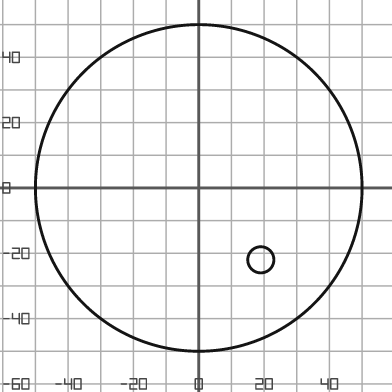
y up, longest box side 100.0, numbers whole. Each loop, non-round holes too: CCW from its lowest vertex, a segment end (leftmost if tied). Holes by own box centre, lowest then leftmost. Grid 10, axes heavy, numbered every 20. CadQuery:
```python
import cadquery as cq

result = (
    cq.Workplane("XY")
    .moveTo(0.0, 0.0)
    .circle(50.0)
    .moveTo(19.0, -22.0)
    .circle(4.0)
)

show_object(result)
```